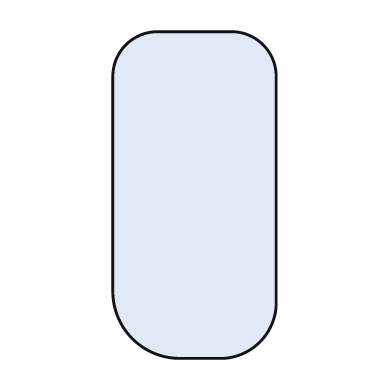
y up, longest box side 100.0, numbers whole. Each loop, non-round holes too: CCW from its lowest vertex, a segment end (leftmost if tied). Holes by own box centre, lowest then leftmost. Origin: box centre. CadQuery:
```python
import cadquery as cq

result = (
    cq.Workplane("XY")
    .moveTo(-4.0, -50.0)
    .lineTo(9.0, -50.0)
    .threePointArc((20.0, -45.0), (25.0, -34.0))
    .lineTo(25.0, 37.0)
    .threePointArc((21.0, 46.0), (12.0, 50.0))
    .lineTo(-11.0, 50.0)
    .threePointArc((-21.0, 46.0), (-25.0, 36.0))
    .lineTo(-25.0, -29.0)
    .threePointArc((-19.0, -44.0), (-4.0, -50.0))
    .close()
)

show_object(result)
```